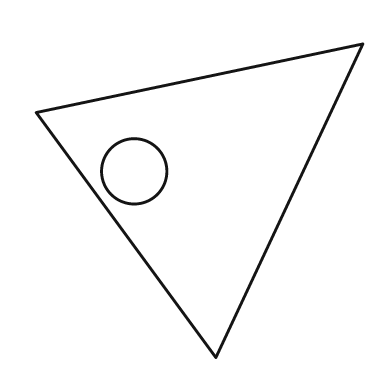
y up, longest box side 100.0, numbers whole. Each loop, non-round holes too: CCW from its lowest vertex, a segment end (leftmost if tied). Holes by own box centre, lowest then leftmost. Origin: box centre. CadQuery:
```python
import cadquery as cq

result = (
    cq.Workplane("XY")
    .moveTo(5.0, -48.0)
    .lineTo(50.0, 48.0)
    .lineTo(-50.0, 27.0)
    .close()
    .moveTo(-20.0, 9.0)
    .circle(10.0)
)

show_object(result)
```